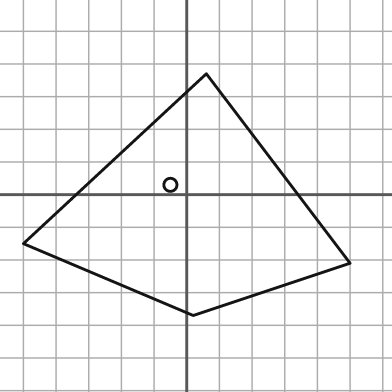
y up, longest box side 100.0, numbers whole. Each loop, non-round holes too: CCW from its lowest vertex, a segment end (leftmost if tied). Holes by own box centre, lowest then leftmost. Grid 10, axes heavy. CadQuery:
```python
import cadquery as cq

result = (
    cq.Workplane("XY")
    .moveTo(2.0, -37.0)
    .lineTo(50.0, -21.0)
    .lineTo(6.0, 37.0)
    .lineTo(-50.0, -15.0)
    .close()
    .moveTo(-5.0, 3.0)
    .circle(2.0)
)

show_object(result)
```